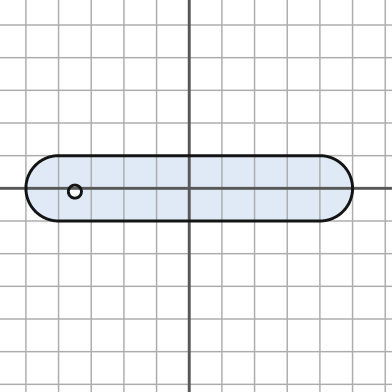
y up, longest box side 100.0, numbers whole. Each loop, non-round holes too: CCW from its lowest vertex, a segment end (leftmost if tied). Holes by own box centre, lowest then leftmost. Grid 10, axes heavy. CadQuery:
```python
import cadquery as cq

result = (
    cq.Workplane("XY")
    .moveTo(-40.0, -10.0)
    .lineTo(40.0, -10.0)
    .threePointArc((50.0, 0.0), (40.0, 10.0))
    .lineTo(-40.0, 10.0)
    .threePointArc((-50.0, 0.0), (-40.0, -10.0))
    .close()
    .moveTo(-35.0, -1.0)
    .circle(2.0)
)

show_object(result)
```